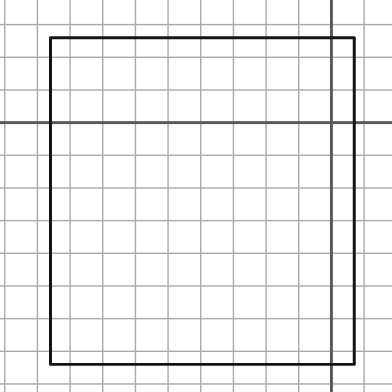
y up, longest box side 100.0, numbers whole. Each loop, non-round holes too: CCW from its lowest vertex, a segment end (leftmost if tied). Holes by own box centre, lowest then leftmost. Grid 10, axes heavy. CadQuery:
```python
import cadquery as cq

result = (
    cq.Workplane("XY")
    .moveTo(-86.0, -74.0)
    .lineTo(7.0, -74.0)
    .lineTo(7.0, 26.0)
    .lineTo(-86.0, 26.0)
    .close()
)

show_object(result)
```